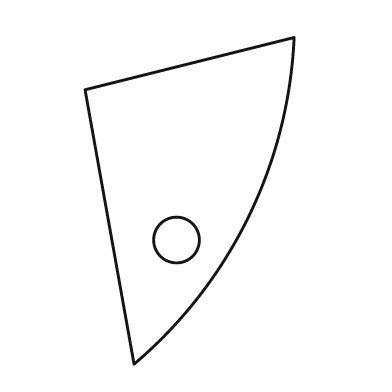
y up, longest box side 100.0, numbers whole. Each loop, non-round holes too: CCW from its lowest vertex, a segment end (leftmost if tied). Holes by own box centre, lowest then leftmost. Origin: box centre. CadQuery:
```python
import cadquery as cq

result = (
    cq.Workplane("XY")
    .moveTo(-17.0, -50.0)
    .threePointArc((18.0, -5.0), (32.0, 50.0))
    .lineTo(-32.0, 34.0)
    .close()
    .moveTo(-4.0, -12.0)
    .circle(7.0)
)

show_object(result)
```